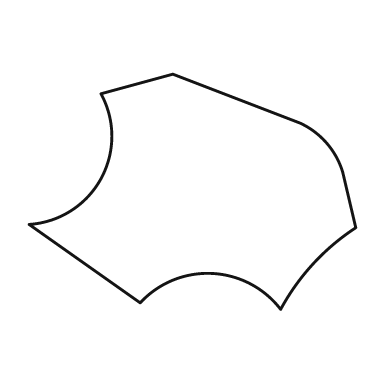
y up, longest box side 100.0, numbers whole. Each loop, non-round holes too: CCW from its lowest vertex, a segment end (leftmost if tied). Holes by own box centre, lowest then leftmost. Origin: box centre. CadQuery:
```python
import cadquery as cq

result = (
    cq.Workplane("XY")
    .moveTo(27.0, -36.0)
    .threePointArc((37.0, -22.0), (50.0, -11.0))
    .lineTo(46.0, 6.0)
    .threePointArc((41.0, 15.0), (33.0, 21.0))
    .lineTo(-6.0, 36.0)
    .lineTo(-28.0, 30.0)
    .threePointArc((-28.0, 4.0), (-50.0, -10.0))
    .lineTo(-16.0, -34.0)
    .threePointArc((6.0, -25.0), (27.0, -36.0))
    .close()
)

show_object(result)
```